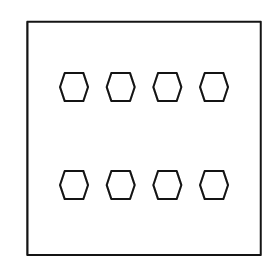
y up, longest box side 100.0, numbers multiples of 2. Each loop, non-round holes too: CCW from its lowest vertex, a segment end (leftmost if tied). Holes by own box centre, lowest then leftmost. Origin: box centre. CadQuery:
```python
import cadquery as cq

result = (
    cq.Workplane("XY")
    .moveTo(-50.0, -50.0)
    .lineTo(50.0, -50.0)
    .lineTo(50.0, 50.0)
    .lineTo(-50.0, 50.0)
    .close()
    .moveTo(-34.0, -26.0)
    .lineTo(-26.0, -26.0)
    .lineTo(-24.0, -20.0)
    .lineTo(-26.0, -14.0)
    .lineTo(-34.0, -14.0)
    .lineTo(-36.0, -20.0)
    .close()
    .moveTo(-14.0, -26.0)
    .lineTo(-6.0, -26.0)
    .lineTo(-4.0, -20.0)
    .lineTo(-6.0, -14.0)
    .lineTo(-14.0, -14.0)
    .lineTo(-16.0, -20.0)
    .close()
    .moveTo(6.0, -26.0)
    .lineTo(14.0, -26.0)
    .lineTo(16.0, -20.0)
    .lineTo(14.0, -14.0)
    .lineTo(6.0, -14.0)
    .lineTo(4.0, -20.0)
    .close()
    .moveTo(26.0, -26.0)
    .lineTo(34.0, -26.0)
    .lineTo(36.0, -20.0)
    .lineTo(34.0, -14.0)
    .lineTo(26.0, -14.0)
    .lineTo(24.0, -20.0)
    .close()
    .moveTo(-34.0, 16.0)
    .lineTo(-26.0, 16.0)
    .lineTo(-24.0, 22.0)
    .lineTo(-26.0, 28.0)
    .lineTo(-34.0, 28.0)
    .lineTo(-36.0, 22.0)
    .close()
    .moveTo(-14.0, 16.0)
    .lineTo(-6.0, 16.0)
    .lineTo(-4.0, 22.0)
    .lineTo(-6.0, 28.0)
    .lineTo(-14.0, 28.0)
    .lineTo(-16.0, 22.0)
    .close()
    .moveTo(6.0, 16.0)
    .lineTo(14.0, 16.0)
    .lineTo(16.0, 22.0)
    .lineTo(14.0, 28.0)
    .lineTo(6.0, 28.0)
    .lineTo(4.0, 22.0)
    .close()
    .moveTo(26.0, 16.0)
    .lineTo(34.0, 16.0)
    .lineTo(36.0, 22.0)
    .lineTo(34.0, 28.0)
    .lineTo(26.0, 28.0)
    .lineTo(24.0, 22.0)
    .close()
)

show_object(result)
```